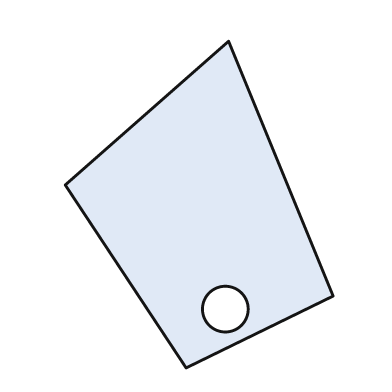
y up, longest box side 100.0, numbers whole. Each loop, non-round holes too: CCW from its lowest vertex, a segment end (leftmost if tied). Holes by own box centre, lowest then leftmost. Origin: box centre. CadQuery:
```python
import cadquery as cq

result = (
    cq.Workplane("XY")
    .moveTo(-4.0, -50.0)
    .lineTo(41.0, -28.0)
    .lineTo(9.0, 50.0)
    .lineTo(-41.0, 6.0)
    .close()
    .moveTo(8.0, -32.0)
    .circle(7.0)
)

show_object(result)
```